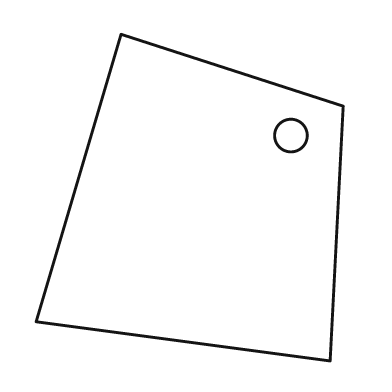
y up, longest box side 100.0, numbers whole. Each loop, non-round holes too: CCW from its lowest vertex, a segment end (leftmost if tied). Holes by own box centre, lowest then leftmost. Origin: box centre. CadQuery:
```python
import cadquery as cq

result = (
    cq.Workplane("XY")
    .moveTo(43.0, -50.0)
    .lineTo(47.0, 28.0)
    .lineTo(-21.0, 50.0)
    .lineTo(-47.0, -38.0)
    .close()
    .moveTo(31.0, 19.0)
    .circle(5.0)
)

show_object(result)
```